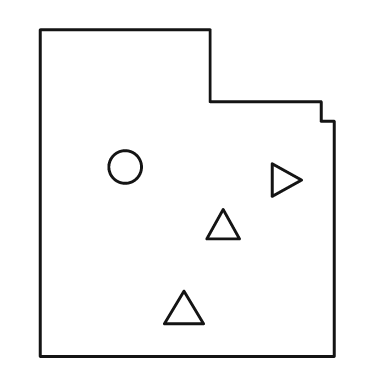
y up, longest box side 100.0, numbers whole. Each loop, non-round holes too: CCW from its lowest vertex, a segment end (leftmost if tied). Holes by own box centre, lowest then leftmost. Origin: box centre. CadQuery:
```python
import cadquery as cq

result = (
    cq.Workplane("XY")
    .moveTo(-45.0, -50.0)
    .lineTo(45.0, -50.0)
    .lineTo(45.0, 22.0)
    .lineTo(41.0, 22.0)
    .lineTo(41.0, 28.0)
    .lineTo(7.0, 28.0)
    .lineTo(7.0, 50.0)
    .lineTo(-45.0, 50.0)
    .close()
    .moveTo(-7.0, -40.0)
    .lineTo(5.0, -40.0)
    .lineTo(-1.0, -30.0)
    .close()
    .moveTo(6.0, -14.0)
    .lineTo(16.0, -14.0)
    .lineTo(11.0, -5.0)
    .close()
    .moveTo(26.0, -1.0)
    .lineTo(35.0, 4.0)
    .lineTo(26.0, 9.0)
    .close()
    .moveTo(-19.0, 8.0)
    .circle(5.0)
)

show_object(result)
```